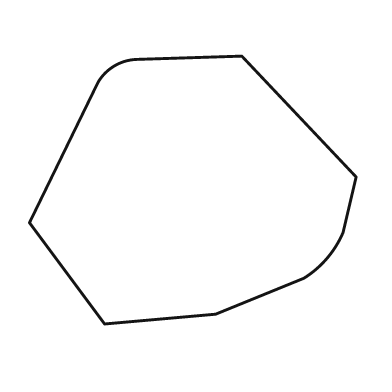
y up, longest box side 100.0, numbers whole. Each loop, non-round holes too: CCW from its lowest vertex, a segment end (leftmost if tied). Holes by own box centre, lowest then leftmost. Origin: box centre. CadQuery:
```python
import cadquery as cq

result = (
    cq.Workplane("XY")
    .moveTo(-27.0, -41.0)
    .lineTo(7.0, -38.0)
    .lineTo(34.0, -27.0)
    .threePointArc((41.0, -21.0), (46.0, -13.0))
    .lineTo(50.0, 4.0)
    .lineTo(15.0, 41.0)
    .lineTo(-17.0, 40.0)
    .threePointArc((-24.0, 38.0), (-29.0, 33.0))
    .lineTo(-50.0, -10.0)
    .close()
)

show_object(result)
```